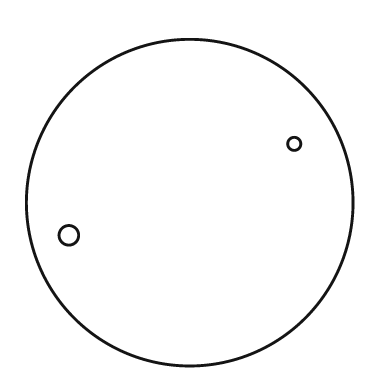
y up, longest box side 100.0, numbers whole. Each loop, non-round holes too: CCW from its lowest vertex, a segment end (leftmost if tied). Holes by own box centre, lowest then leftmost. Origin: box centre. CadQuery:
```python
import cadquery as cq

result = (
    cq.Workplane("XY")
    .moveTo(0.0, 0.0)
    .circle(50.0)
    .moveTo(-37.0, -10.0)
    .circle(3.0)
    .moveTo(32.0, 18.0)
    .circle(2.0)
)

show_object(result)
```